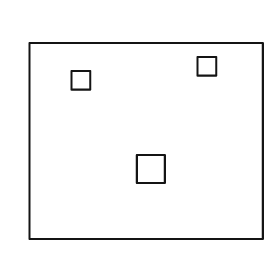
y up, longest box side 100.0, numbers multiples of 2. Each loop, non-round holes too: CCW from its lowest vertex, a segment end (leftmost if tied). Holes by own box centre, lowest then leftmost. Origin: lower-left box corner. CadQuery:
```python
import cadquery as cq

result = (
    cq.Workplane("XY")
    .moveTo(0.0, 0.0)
    .lineTo(100.0, 0.0)
    .lineTo(100.0, 84.0)
    .lineTo(0.0, 84.0)
    .close()
    .moveTo(46.0, 24.0)
    .lineTo(58.0, 24.0)
    .lineTo(58.0, 36.0)
    .lineTo(46.0, 36.0)
    .close()
    .moveTo(18.0, 64.0)
    .lineTo(26.0, 64.0)
    .lineTo(26.0, 72.0)
    .lineTo(18.0, 72.0)
    .close()
    .moveTo(72.0, 70.0)
    .lineTo(80.0, 70.0)
    .lineTo(80.0, 78.0)
    .lineTo(72.0, 78.0)
    .close()
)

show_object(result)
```